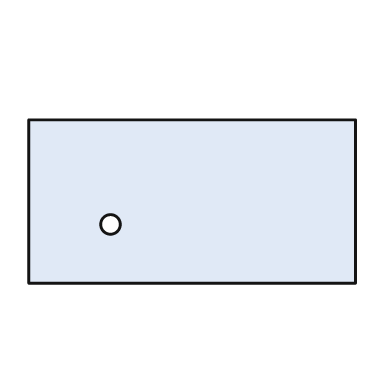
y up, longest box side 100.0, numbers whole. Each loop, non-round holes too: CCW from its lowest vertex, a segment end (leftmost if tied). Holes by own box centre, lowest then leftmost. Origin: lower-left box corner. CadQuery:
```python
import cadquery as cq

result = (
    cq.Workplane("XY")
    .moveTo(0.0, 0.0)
    .lineTo(100.0, 0.0)
    .lineTo(100.0, 50.0)
    .lineTo(0.0, 50.0)
    .close()
    .moveTo(25.0, 18.0)
    .circle(3.0)
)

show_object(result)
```